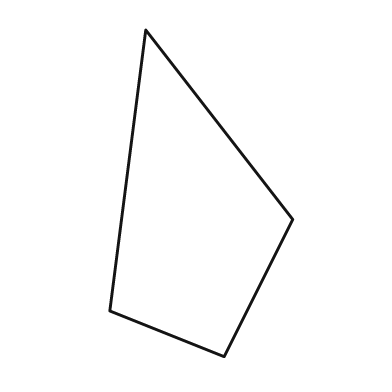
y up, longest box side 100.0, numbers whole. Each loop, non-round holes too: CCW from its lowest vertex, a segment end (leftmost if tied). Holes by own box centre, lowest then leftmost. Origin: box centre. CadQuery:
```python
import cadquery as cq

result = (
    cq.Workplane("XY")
    .moveTo(7.0, -50.0)
    .lineTo(28.0, -8.0)
    .lineTo(-17.0, 50.0)
    .lineTo(-28.0, -36.0)
    .close()
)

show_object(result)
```